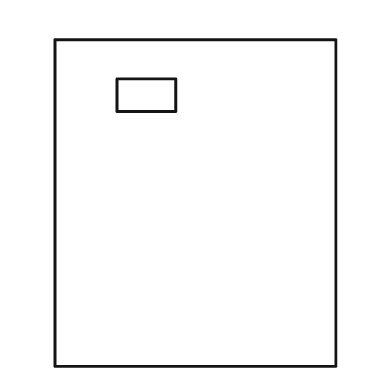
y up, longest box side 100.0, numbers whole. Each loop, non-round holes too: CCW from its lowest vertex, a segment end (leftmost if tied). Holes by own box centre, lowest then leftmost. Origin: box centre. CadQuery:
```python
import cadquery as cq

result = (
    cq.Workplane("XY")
    .moveTo(-43.0, -50.0)
    .lineTo(43.0, -50.0)
    .lineTo(43.0, 50.0)
    .lineTo(-43.0, 50.0)
    .close()
    .moveTo(-24.0, 28.0)
    .lineTo(-6.0, 28.0)
    .lineTo(-6.0, 38.0)
    .lineTo(-24.0, 38.0)
    .close()
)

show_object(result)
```